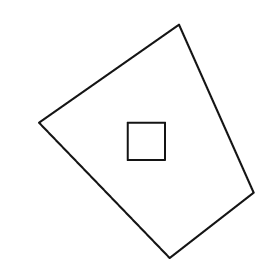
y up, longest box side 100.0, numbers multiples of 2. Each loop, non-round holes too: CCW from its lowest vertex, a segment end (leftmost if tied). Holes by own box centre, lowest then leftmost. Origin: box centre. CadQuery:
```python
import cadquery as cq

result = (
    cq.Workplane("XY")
    .moveTo(10.0, -50.0)
    .lineTo(46.0, -22.0)
    .lineTo(14.0, 50.0)
    .lineTo(-46.0, 8.0)
    .close()
    .moveTo(-8.0, -8.0)
    .lineTo(8.0, -8.0)
    .lineTo(8.0, 8.0)
    .lineTo(-8.0, 8.0)
    .close()
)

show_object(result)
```